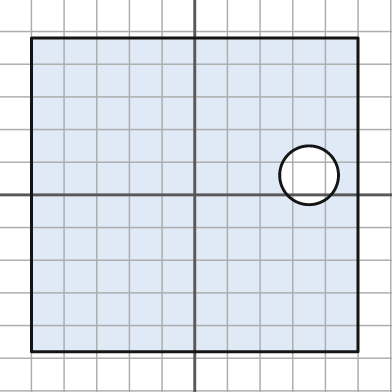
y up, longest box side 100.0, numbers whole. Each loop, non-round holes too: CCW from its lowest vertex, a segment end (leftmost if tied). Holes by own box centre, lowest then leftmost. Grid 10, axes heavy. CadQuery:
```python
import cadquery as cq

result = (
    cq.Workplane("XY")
    .moveTo(-50.0, -48.0)
    .lineTo(50.0, -48.0)
    .lineTo(50.0, 48.0)
    .lineTo(-50.0, 48.0)
    .close()
    .moveTo(35.0, 6.0)
    .circle(9.0)
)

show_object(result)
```